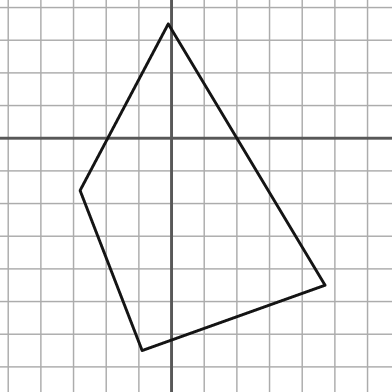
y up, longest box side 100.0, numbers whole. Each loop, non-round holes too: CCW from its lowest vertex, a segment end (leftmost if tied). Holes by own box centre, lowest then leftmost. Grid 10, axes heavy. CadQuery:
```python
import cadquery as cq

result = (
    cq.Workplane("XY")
    .moveTo(-9.0, -65.0)
    .lineTo(47.0, -45.0)
    .lineTo(-1.0, 35.0)
    .lineTo(-28.0, -16.0)
    .close()
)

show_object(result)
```